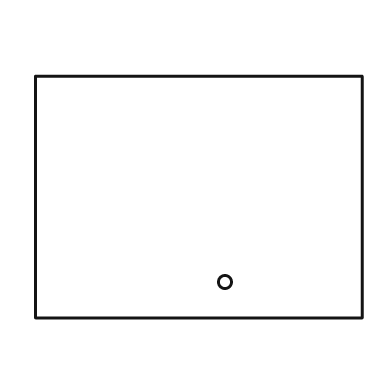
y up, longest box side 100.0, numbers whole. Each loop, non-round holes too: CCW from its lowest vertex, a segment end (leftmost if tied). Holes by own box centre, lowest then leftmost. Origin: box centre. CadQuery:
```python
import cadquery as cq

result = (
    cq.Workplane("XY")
    .moveTo(-50.0, -37.0)
    .lineTo(50.0, -37.0)
    .lineTo(50.0, 37.0)
    .lineTo(-50.0, 37.0)
    .close()
    .moveTo(8.0, -26.0)
    .circle(2.0)
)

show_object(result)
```